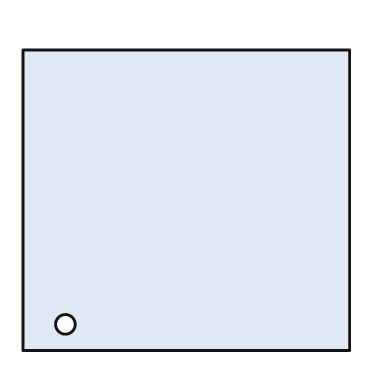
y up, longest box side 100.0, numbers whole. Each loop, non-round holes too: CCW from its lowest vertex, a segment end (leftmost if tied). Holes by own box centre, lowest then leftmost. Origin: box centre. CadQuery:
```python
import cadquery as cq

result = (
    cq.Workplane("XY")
    .moveTo(-50.0, -46.0)
    .lineTo(50.0, -46.0)
    .lineTo(50.0, 46.0)
    .lineTo(-50.0, 46.0)
    .close()
    .moveTo(-37.0, -38.0)
    .circle(3.0)
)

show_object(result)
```